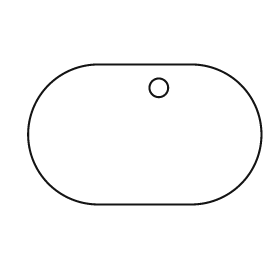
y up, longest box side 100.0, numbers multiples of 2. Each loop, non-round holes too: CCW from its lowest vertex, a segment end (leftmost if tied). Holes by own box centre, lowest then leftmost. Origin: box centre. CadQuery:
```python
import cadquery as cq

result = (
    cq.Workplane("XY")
    .moveTo(-20.0, -30.0)
    .lineTo(20.0, -30.0)
    .threePointArc((50.0, 0.0), (20.0, 30.0))
    .lineTo(-20.0, 30.0)
    .threePointArc((-50.0, 0.0), (-20.0, -30.0))
    .close()
    .moveTo(6.0, 20.0)
    .circle(4.0)
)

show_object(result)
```